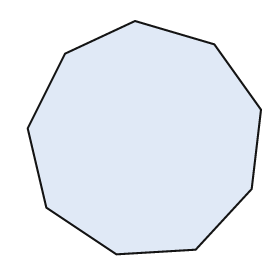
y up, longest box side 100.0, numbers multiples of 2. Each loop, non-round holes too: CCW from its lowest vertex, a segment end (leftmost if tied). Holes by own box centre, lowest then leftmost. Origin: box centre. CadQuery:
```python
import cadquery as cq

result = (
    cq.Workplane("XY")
    .moveTo(-12.0, -50.0)
    .lineTo(22.0, -48.0)
    .lineTo(46.0, -22.0)
    .lineTo(50.0, 12.0)
    .lineTo(30.0, 40.0)
    .lineTo(-4.0, 50.0)
    .lineTo(-34.0, 36.0)
    .lineTo(-50.0, 4.0)
    .lineTo(-42.0, -30.0)
    .close()
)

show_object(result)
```